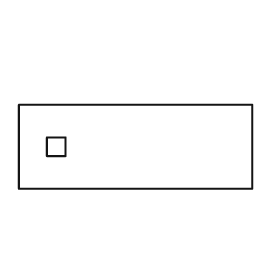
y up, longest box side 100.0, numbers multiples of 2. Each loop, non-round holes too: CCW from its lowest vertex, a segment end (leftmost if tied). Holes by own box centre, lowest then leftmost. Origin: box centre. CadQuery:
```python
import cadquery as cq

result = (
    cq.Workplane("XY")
    .moveTo(-50.0, -18.0)
    .lineTo(50.0, -18.0)
    .lineTo(50.0, 18.0)
    .lineTo(-50.0, 18.0)
    .close()
    .moveTo(-38.0, -4.0)
    .lineTo(-30.0, -4.0)
    .lineTo(-30.0, 4.0)
    .lineTo(-38.0, 4.0)
    .close()
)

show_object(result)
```